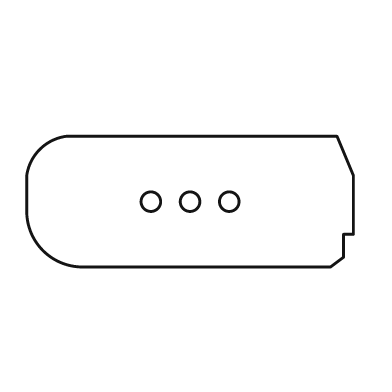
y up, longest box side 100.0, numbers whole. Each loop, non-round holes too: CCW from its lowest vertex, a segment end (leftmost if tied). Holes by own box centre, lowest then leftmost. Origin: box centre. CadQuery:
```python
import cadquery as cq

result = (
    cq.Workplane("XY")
    .moveTo(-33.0, -20.0)
    .lineTo(43.0, -20.0)
    .lineTo(47.0, -17.0)
    .lineTo(47.0, -10.0)
    .lineTo(50.0, -10.0)
    .lineTo(50.0, 8.0)
    .lineTo(45.0, 20.0)
    .lineTo(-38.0, 20.0)
    .threePointArc((-46.0, 16.0), (-50.0, 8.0))
    .lineTo(-50.0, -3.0)
    .threePointArc((-45.0, -15.0), (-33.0, -20.0))
    .close()
    .moveTo(-12.0, 0.0)
    .circle(3.0)
    .moveTo(0.0, 0.0)
    .circle(3.0)
    .moveTo(12.0, 0.0)
    .circle(3.0)
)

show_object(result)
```